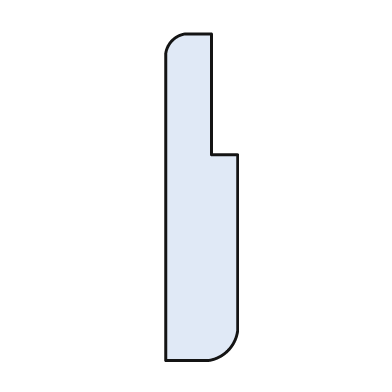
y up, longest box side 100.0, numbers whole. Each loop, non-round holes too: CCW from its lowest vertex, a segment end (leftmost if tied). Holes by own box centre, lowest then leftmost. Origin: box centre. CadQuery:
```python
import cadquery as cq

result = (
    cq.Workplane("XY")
    .moveTo(-11.0, -50.0)
    .lineTo(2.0, -50.0)
    .threePointArc((8.0, -47.0), (11.0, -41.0))
    .lineTo(11.0, 13.0)
    .lineTo(3.0, 13.0)
    .lineTo(3.0, 50.0)
    .lineTo(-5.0, 50.0)
    .threePointArc((-9.0, 48.0), (-11.0, 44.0))
    .close()
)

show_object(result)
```